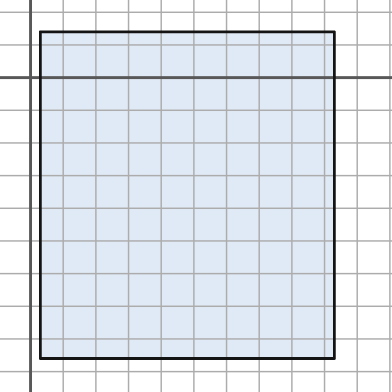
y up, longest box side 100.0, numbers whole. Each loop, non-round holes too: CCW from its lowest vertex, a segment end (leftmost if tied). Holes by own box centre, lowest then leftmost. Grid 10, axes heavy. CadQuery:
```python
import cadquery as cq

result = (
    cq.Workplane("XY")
    .moveTo(3.0, -86.0)
    .lineTo(93.0, -86.0)
    .lineTo(93.0, 14.0)
    .lineTo(3.0, 14.0)
    .close()
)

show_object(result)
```